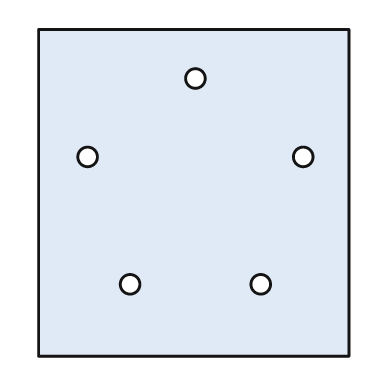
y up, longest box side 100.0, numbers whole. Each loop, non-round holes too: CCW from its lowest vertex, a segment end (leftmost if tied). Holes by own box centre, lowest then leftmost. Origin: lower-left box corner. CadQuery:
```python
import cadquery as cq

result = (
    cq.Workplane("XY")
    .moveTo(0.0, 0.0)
    .lineTo(95.0, 0.0)
    .lineTo(95.0, 100.0)
    .lineTo(0.0, 100.0)
    .close()
    .moveTo(28.0, 22.0)
    .circle(3.0)
    .moveTo(68.0, 22.0)
    .circle(3.0)
    .moveTo(15.0, 61.0)
    .circle(3.0)
    .moveTo(81.0, 61.0)
    .circle(3.0)
    .moveTo(48.0, 85.0)
    .circle(3.0)
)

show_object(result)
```